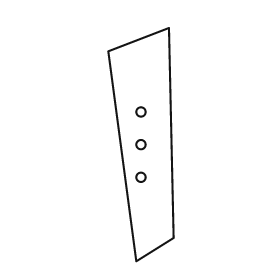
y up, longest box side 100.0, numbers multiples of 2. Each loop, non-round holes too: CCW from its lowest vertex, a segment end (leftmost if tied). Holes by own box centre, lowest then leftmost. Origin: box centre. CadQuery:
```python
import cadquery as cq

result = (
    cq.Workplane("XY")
    .moveTo(-2.0, -50.0)
    .lineTo(14.0, -40.0)
    .lineTo(12.0, 50.0)
    .lineTo(-14.0, 40.0)
    .close()
    .moveTo(0.0, -14.0)
    .circle(2.0)
    .moveTo(0.0, 0.0)
    .circle(2.0)
    .moveTo(0.0, 14.0)
    .circle(2.0)
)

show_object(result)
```